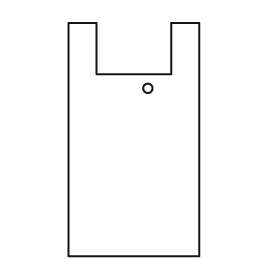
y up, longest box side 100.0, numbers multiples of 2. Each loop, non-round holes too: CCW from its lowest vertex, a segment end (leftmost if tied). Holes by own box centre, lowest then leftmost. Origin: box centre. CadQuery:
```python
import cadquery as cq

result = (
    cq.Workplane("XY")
    .moveTo(-28.0, -50.0)
    .lineTo(28.0, -50.0)
    .lineTo(28.0, 50.0)
    .lineTo(16.0, 50.0)
    .lineTo(16.0, 28.0)
    .lineTo(-16.0, 28.0)
    .lineTo(-16.0, 50.0)
    .lineTo(-28.0, 50.0)
    .close()
    .moveTo(6.0, 22.0)
    .circle(2.0)
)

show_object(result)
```